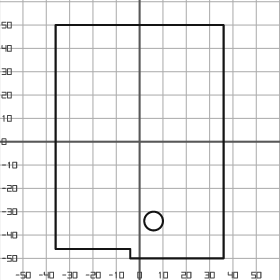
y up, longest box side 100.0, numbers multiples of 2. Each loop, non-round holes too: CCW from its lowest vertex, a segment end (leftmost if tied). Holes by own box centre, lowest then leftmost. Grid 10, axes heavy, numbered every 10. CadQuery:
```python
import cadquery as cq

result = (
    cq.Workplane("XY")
    .moveTo(-4.0, -50.0)
    .lineTo(36.0, -50.0)
    .lineTo(36.0, 50.0)
    .lineTo(-36.0, 50.0)
    .lineTo(-36.0, -46.0)
    .lineTo(-4.0, -46.0)
    .close()
    .moveTo(6.0, -34.0)
    .circle(4.0)
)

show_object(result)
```